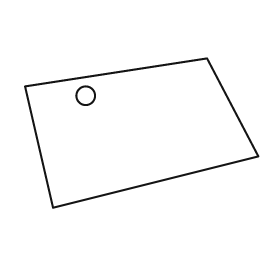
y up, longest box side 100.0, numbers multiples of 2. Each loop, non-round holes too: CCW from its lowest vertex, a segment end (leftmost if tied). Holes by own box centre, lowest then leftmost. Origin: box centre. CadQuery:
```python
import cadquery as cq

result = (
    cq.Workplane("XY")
    .moveTo(-38.0, -32.0)
    .lineTo(50.0, -10.0)
    .lineTo(28.0, 32.0)
    .lineTo(-50.0, 20.0)
    .close()
    .moveTo(-24.0, 16.0)
    .circle(4.0)
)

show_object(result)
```